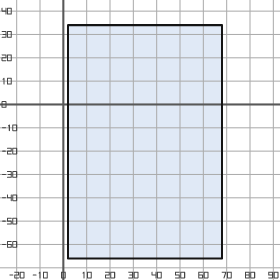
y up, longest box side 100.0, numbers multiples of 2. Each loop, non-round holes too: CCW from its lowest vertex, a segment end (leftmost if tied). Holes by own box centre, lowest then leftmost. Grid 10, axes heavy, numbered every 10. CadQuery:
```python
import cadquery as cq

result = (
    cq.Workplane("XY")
    .moveTo(2.0, -66.0)
    .lineTo(68.0, -66.0)
    .lineTo(68.0, 34.0)
    .lineTo(2.0, 34.0)
    .close()
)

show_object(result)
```